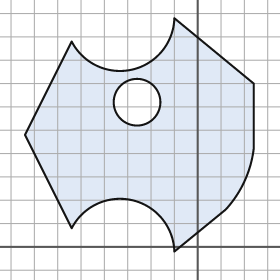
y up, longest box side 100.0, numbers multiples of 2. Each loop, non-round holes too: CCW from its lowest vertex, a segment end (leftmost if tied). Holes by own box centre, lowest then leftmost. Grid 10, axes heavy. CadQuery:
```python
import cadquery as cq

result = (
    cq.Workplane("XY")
    .moveTo(-10.0, -2.0)
    .lineTo(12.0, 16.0)
    .threePointArc((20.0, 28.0), (24.0, 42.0))
    .lineTo(24.0, 70.0)
    .lineTo(-10.0, 98.0)
    .threePointArc((-28.0, 76.0), (-54.0, 88.0))
    .lineTo(-74.0, 48.0)
    .lineTo(-54.0, 8.0)
    .threePointArc((-28.0, 20.0), (-10.0, -2.0))
    .close()
    .moveTo(-26.0, 62.0)
    .circle(10.0)
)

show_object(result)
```